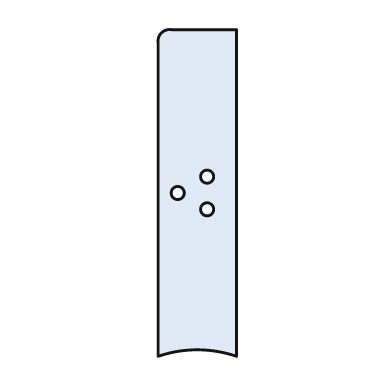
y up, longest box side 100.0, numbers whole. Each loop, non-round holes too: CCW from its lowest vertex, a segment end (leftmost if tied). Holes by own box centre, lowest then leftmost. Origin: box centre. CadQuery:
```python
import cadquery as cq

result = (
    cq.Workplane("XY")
    .moveTo(-12.0, -50.0)
    .threePointArc((0.0, -48.0), (12.0, -50.0))
    .lineTo(12.0, 50.0)
    .lineTo(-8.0, 50.0)
    .threePointArc((-11.0, 49.0), (-12.0, 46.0))
    .close()
    .moveTo(3.0, -5.0)
    .circle(2.0)
    .moveTo(-6.0, 0.0)
    .circle(2.0)
    .moveTo(3.0, 5.0)
    .circle(2.0)
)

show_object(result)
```